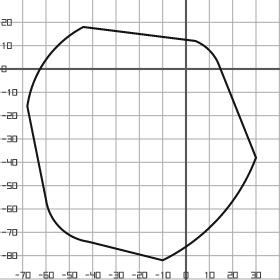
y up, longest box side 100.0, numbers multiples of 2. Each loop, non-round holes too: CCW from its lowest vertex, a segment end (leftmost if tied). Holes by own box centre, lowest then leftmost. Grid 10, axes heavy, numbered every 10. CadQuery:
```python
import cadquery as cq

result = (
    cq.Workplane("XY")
    .moveTo(-10.0, -82.0)
    .threePointArc((14.0, -64.0), (30.0, -38.0))
    .lineTo(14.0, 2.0)
    .threePointArc((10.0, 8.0), (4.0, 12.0))
    .lineTo(-44.0, 18.0)
    .threePointArc((-60.0, 4.0), (-68.0, -16.0))
    .lineTo(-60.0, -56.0)
    .threePointArc((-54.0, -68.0), (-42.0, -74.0))
    .close()
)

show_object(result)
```